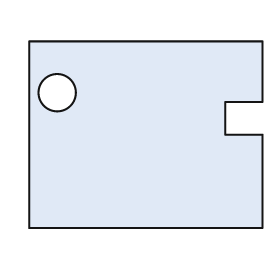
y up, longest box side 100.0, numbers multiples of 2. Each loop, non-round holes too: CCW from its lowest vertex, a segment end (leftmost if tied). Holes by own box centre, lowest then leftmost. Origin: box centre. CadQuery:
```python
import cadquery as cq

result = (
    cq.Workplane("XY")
    .moveTo(-50.0, -40.0)
    .lineTo(50.0, -40.0)
    .lineTo(50.0, 0.0)
    .lineTo(34.0, 0.0)
    .lineTo(34.0, 14.0)
    .lineTo(50.0, 14.0)
    .lineTo(50.0, 40.0)
    .lineTo(-50.0, 40.0)
    .close()
    .moveTo(-38.0, 18.0)
    .circle(8.0)
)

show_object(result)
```